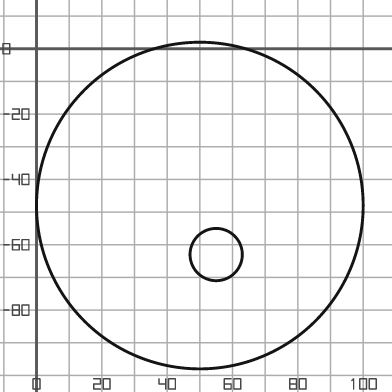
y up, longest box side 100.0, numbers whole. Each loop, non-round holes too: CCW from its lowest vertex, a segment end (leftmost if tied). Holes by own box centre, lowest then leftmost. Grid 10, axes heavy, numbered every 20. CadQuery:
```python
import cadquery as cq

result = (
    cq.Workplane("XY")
    .moveTo(50.0, -48.0)
    .circle(50.0)
    .moveTo(55.0, -63.0)
    .circle(8.0)
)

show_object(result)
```